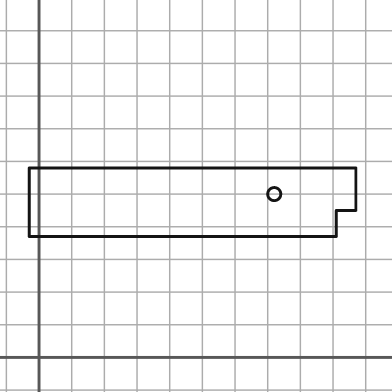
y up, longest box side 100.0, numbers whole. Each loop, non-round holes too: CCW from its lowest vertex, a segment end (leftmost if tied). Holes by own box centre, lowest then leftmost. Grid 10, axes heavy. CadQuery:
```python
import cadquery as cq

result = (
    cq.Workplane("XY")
    .moveTo(-3.0, 37.0)
    .lineTo(91.0, 37.0)
    .lineTo(91.0, 45.0)
    .lineTo(97.0, 45.0)
    .lineTo(97.0, 58.0)
    .lineTo(-3.0, 58.0)
    .close()
    .moveTo(72.0, 50.0)
    .circle(2.0)
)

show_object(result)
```